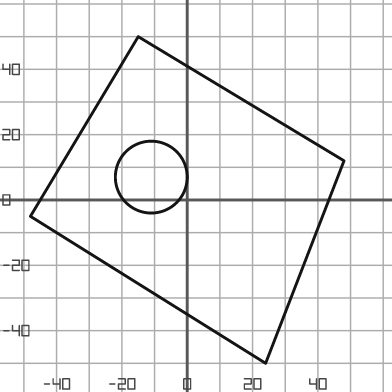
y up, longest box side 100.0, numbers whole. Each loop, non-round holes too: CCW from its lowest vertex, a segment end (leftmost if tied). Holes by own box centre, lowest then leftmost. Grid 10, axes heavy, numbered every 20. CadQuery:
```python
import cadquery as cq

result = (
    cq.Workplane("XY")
    .moveTo(24.0, -50.0)
    .lineTo(48.0, 12.0)
    .lineTo(-15.0, 50.0)
    .lineTo(-48.0, -5.0)
    .close()
    .moveTo(-11.0, 7.0)
    .circle(11.0)
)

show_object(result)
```